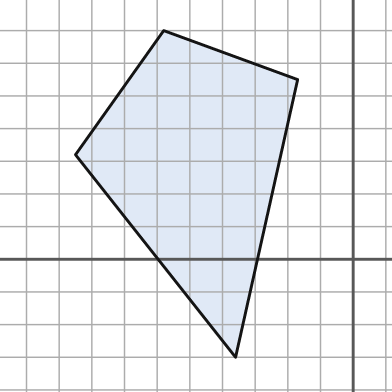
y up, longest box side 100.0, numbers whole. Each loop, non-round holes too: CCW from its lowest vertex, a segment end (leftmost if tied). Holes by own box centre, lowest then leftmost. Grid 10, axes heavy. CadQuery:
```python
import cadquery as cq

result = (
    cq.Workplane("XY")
    .moveTo(-36.0, -30.0)
    .lineTo(-17.0, 55.0)
    .lineTo(-58.0, 70.0)
    .lineTo(-85.0, 32.0)
    .close()
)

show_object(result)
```